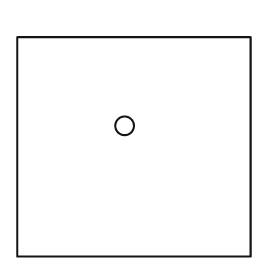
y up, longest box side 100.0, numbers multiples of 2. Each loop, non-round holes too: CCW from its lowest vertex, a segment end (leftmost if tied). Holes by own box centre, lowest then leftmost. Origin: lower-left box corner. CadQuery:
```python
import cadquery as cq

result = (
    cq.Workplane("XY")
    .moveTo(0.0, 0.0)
    .lineTo(100.0, 0.0)
    .lineTo(100.0, 94.0)
    .lineTo(0.0, 94.0)
    .close()
    .moveTo(46.0, 56.0)
    .circle(4.0)
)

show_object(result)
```